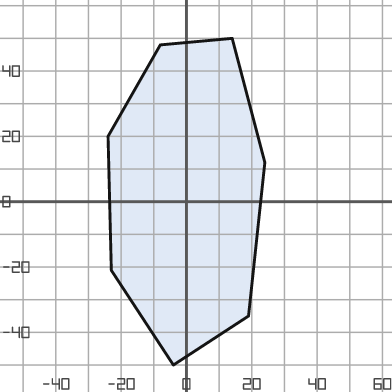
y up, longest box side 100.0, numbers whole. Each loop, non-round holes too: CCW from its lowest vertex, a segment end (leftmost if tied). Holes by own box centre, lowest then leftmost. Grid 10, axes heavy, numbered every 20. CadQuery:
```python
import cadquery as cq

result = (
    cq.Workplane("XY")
    .moveTo(-4.0, -50.0)
    .lineTo(19.0, -35.0)
    .lineTo(24.0, 12.0)
    .lineTo(14.0, 50.0)
    .lineTo(-8.0, 48.0)
    .lineTo(-24.0, 20.0)
    .lineTo(-23.0, -21.0)
    .close()
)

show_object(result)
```